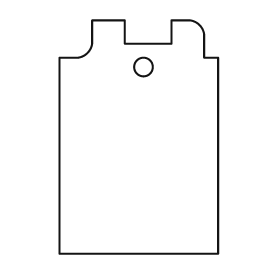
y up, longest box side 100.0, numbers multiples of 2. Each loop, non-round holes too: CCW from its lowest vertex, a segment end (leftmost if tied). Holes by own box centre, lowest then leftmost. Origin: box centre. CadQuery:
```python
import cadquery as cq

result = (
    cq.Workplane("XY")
    .moveTo(-34.0, -50.0)
    .lineTo(34.0, -50.0)
    .lineTo(34.0, 34.0)
    .lineTo(28.0, 34.0)
    .lineTo(28.0, 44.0)
    .threePointArc((26.0, 48.0), (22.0, 50.0))
    .lineTo(14.0, 50.0)
    .lineTo(14.0, 40.0)
    .lineTo(-6.0, 40.0)
    .lineTo(-6.0, 50.0)
    .lineTo(-20.0, 50.0)
    .lineTo(-20.0, 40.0)
    .threePointArc((-22.0, 36.0), (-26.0, 34.0))
    .lineTo(-34.0, 34.0)
    .close()
    .moveTo(2.0, 30.0)
    .circle(4.0)
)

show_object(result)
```